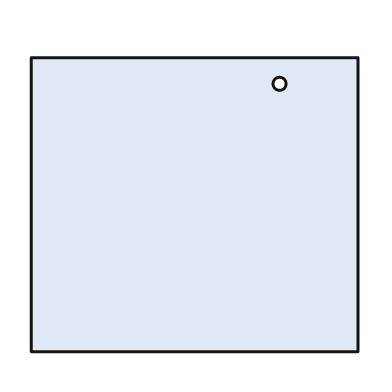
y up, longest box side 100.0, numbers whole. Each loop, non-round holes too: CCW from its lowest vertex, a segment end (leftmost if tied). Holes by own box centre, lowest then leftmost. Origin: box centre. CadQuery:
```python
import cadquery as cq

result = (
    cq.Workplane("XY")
    .moveTo(-50.0, -45.0)
    .lineTo(50.0, -45.0)
    .lineTo(50.0, 45.0)
    .lineTo(-50.0, 45.0)
    .close()
    .moveTo(26.0, 37.0)
    .circle(2.0)
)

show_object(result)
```